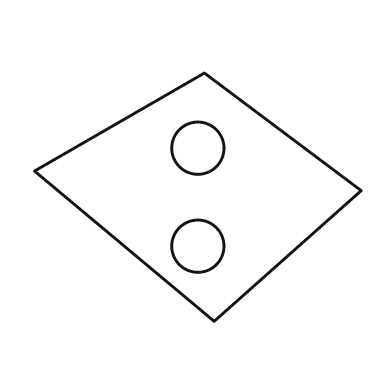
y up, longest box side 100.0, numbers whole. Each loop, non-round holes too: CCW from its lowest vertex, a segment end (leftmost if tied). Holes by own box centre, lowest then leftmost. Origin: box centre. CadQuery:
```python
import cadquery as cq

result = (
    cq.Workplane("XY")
    .moveTo(5.0, -38.0)
    .lineTo(50.0, 2.0)
    .lineTo(2.0, 38.0)
    .lineTo(-50.0, 8.0)
    .close()
    .moveTo(0.0, -15.0)
    .circle(8.0)
    .moveTo(0.0, 15.0)
    .circle(8.0)
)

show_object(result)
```